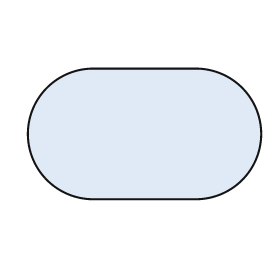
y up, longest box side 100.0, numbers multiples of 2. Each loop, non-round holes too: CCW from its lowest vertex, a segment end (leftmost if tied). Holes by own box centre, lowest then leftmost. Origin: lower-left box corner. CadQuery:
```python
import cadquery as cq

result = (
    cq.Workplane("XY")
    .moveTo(28.0, 0.0)
    .lineTo(72.0, 0.0)
    .threePointArc((100.0, 28.0), (72.0, 56.0))
    .lineTo(28.0, 56.0)
    .threePointArc((0.0, 28.0), (28.0, 0.0))
    .close()
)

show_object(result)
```